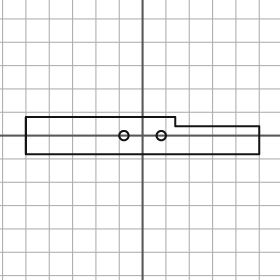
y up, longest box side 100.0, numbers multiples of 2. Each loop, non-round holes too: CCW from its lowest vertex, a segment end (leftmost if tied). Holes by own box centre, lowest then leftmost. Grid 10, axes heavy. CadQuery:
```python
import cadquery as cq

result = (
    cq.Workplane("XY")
    .moveTo(-50.0, -8.0)
    .lineTo(50.0, -8.0)
    .lineTo(50.0, 4.0)
    .lineTo(14.0, 4.0)
    .lineTo(14.0, 8.0)
    .lineTo(-50.0, 8.0)
    .close()
    .moveTo(-8.0, 0.0)
    .circle(2.0)
    .moveTo(8.0, 0.0)
    .circle(2.0)
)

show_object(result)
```